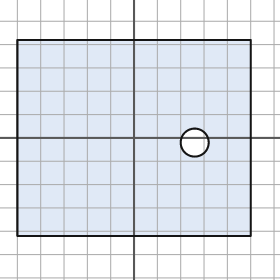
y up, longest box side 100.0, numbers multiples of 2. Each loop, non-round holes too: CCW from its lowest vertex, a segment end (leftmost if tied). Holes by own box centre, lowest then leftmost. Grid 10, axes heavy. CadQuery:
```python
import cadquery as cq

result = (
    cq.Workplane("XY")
    .moveTo(-50.0, -42.0)
    .lineTo(50.0, -42.0)
    .lineTo(50.0, 42.0)
    .lineTo(-50.0, 42.0)
    .close()
    .moveTo(26.0, -2.0)
    .circle(6.0)
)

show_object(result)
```